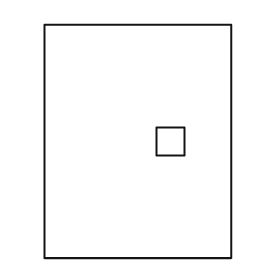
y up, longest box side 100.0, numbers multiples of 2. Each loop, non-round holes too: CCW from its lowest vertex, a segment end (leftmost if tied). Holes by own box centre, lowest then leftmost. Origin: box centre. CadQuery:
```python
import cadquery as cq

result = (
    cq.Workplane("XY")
    .moveTo(-40.0, -50.0)
    .lineTo(40.0, -50.0)
    .lineTo(40.0, 50.0)
    .lineTo(-40.0, 50.0)
    .close()
    .moveTo(8.0, -6.0)
    .lineTo(20.0, -6.0)
    .lineTo(20.0, 6.0)
    .lineTo(8.0, 6.0)
    .close()
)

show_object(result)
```